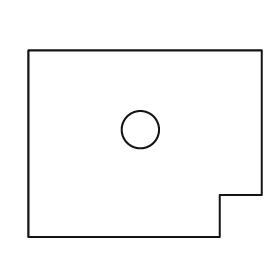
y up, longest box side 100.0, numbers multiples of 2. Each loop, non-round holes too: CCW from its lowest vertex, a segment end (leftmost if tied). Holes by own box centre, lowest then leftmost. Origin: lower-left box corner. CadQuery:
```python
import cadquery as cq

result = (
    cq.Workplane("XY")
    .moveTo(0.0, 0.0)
    .lineTo(82.0, 0.0)
    .lineTo(82.0, 18.0)
    .lineTo(100.0, 18.0)
    .lineTo(100.0, 80.0)
    .lineTo(0.0, 80.0)
    .close()
    .moveTo(48.0, 46.0)
    .circle(8.0)
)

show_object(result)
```